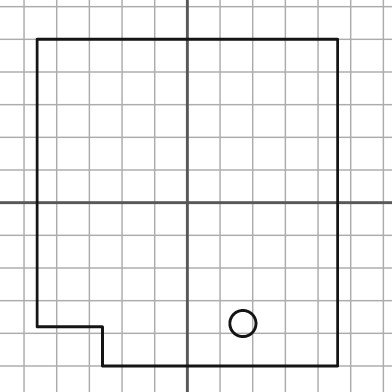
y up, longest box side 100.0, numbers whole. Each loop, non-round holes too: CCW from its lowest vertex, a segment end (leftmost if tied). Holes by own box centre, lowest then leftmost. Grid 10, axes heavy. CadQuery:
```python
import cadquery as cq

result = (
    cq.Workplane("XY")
    .moveTo(-26.0, -50.0)
    .lineTo(46.0, -50.0)
    .lineTo(46.0, 50.0)
    .lineTo(-46.0, 50.0)
    .lineTo(-46.0, -38.0)
    .lineTo(-26.0, -38.0)
    .close()
    .moveTo(17.0, -37.0)
    .circle(4.0)
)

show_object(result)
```